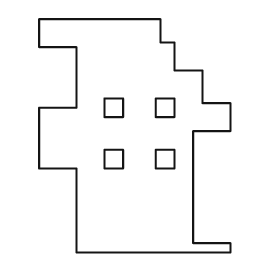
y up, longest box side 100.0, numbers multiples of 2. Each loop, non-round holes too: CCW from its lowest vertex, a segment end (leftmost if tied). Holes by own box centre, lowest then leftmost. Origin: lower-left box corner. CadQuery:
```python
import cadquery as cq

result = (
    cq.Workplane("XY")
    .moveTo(16.0, 0.0)
    .lineTo(82.0, 0.0)
    .lineTo(82.0, 4.0)
    .lineTo(66.0, 4.0)
    .lineTo(66.0, 52.0)
    .lineTo(82.0, 52.0)
    .lineTo(82.0, 64.0)
    .lineTo(70.0, 64.0)
    .lineTo(70.0, 78.0)
    .lineTo(58.0, 78.0)
    .lineTo(58.0, 90.0)
    .lineTo(52.0, 90.0)
    .lineTo(52.0, 100.0)
    .lineTo(0.0, 100.0)
    .lineTo(0.0, 88.0)
    .lineTo(16.0, 88.0)
    .lineTo(16.0, 62.0)
    .lineTo(0.0, 62.0)
    .lineTo(0.0, 36.0)
    .lineTo(16.0, 36.0)
    .close()
    .moveTo(28.0, 36.0)
    .lineTo(36.0, 36.0)
    .lineTo(36.0, 44.0)
    .lineTo(28.0, 44.0)
    .close()
    .moveTo(50.0, 36.0)
    .lineTo(58.0, 36.0)
    .lineTo(58.0, 44.0)
    .lineTo(50.0, 44.0)
    .close()
    .moveTo(28.0, 58.0)
    .lineTo(36.0, 58.0)
    .lineTo(36.0, 66.0)
    .lineTo(28.0, 66.0)
    .close()
    .moveTo(50.0, 58.0)
    .lineTo(58.0, 58.0)
    .lineTo(58.0, 66.0)
    .lineTo(50.0, 66.0)
    .close()
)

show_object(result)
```